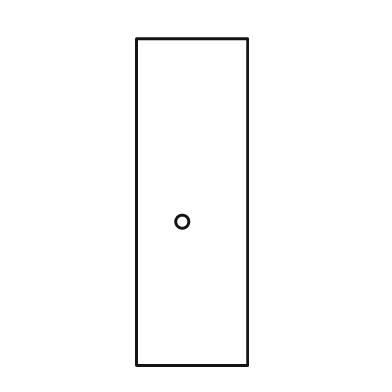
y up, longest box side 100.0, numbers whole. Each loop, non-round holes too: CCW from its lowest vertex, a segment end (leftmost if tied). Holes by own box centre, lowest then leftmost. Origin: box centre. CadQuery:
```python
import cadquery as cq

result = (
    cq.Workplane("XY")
    .moveTo(-17.0, -50.0)
    .lineTo(17.0, -50.0)
    .lineTo(17.0, 50.0)
    .lineTo(-17.0, 50.0)
    .close()
    .moveTo(-3.0, -6.0)
    .circle(2.0)
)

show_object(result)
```